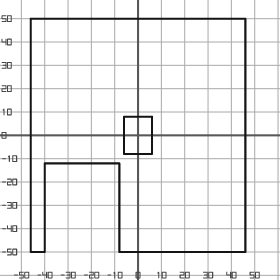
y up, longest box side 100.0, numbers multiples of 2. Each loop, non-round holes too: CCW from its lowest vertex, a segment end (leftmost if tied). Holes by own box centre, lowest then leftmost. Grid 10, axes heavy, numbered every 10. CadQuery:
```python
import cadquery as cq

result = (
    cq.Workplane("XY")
    .moveTo(-46.0, -50.0)
    .lineTo(-40.0, -50.0)
    .lineTo(-40.0, -12.0)
    .lineTo(-8.0, -12.0)
    .lineTo(-8.0, -50.0)
    .lineTo(46.0, -50.0)
    .lineTo(46.0, 50.0)
    .lineTo(-46.0, 50.0)
    .close()
    .moveTo(-6.0, -8.0)
    .lineTo(6.0, -8.0)
    .lineTo(6.0, 8.0)
    .lineTo(-6.0, 8.0)
    .close()
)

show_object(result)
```